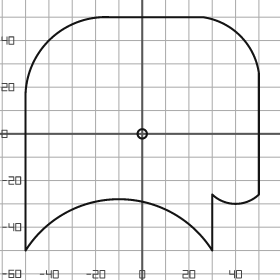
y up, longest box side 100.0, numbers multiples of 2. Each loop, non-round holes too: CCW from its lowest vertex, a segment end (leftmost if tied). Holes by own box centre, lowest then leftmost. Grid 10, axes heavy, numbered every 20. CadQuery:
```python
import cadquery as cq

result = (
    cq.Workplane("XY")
    .moveTo(-50.0, -50.0)
    .threePointArc((-10.0, -28.0), (30.0, -50.0))
    .lineTo(30.0, -26.0)
    .threePointArc((40.0, -30.0), (50.0, -26.0))
    .lineTo(50.0, 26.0)
    .threePointArc((42.0, 42.0), (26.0, 50.0))
    .lineTo(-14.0, 50.0)
    .threePointArc((-40.0, 40.0), (-50.0, 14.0))
    .close()
    .moveTo(0.0, 0.0)
    .circle(2.0)
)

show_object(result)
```